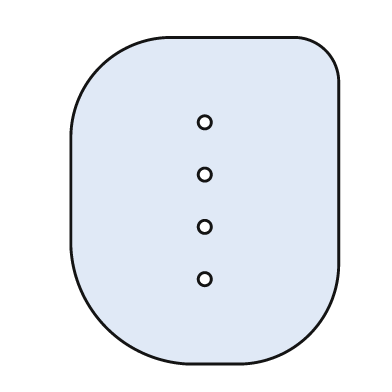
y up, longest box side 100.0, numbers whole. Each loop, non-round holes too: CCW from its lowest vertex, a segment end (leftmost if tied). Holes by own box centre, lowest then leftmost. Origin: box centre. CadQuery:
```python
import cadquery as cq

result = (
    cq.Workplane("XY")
    .moveTo(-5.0, -50.0)
    .lineTo(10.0, -50.0)
    .threePointArc((32.0, -41.0), (41.0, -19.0))
    .lineTo(41.0, 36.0)
    .threePointArc((37.0, 46.0), (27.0, 50.0))
    .lineTo(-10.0, 50.0)
    .threePointArc((-32.0, 41.0), (-41.0, 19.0))
    .lineTo(-41.0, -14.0)
    .threePointArc((-30.0, -39.0), (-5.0, -50.0))
    .close()
    .moveTo(0.0, -24.0)
    .circle(2.0)
    .moveTo(0.0, -8.0)
    .circle(2.0)
    .moveTo(0.0, 8.0)
    .circle(2.0)
    .moveTo(0.0, 24.0)
    .circle(2.0)
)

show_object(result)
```